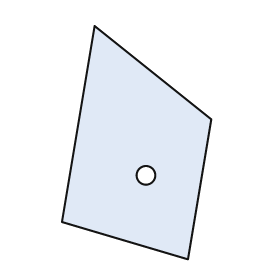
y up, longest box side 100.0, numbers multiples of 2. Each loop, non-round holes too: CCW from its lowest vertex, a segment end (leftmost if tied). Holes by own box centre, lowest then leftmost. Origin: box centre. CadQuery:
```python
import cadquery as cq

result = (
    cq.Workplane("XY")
    .moveTo(22.0, -50.0)
    .lineTo(32.0, 10.0)
    .lineTo(-18.0, 50.0)
    .lineTo(-32.0, -34.0)
    .close()
    .moveTo(4.0, -14.0)
    .circle(4.0)
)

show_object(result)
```